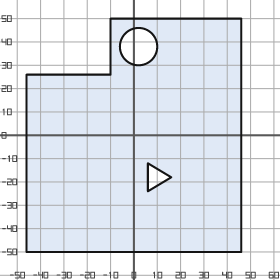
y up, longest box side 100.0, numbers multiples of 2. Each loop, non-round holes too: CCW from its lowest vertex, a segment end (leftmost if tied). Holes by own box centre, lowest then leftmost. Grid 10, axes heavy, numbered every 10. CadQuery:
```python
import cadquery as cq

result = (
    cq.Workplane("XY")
    .moveTo(-46.0, -50.0)
    .lineTo(46.0, -50.0)
    .lineTo(46.0, 50.0)
    .lineTo(-10.0, 50.0)
    .lineTo(-10.0, 26.0)
    .lineTo(-46.0, 26.0)
    .close()
    .moveTo(6.0, -24.0)
    .lineTo(16.0, -18.0)
    .lineTo(6.0, -12.0)
    .close()
    .moveTo(2.0, 38.0)
    .circle(8.0)
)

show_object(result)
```